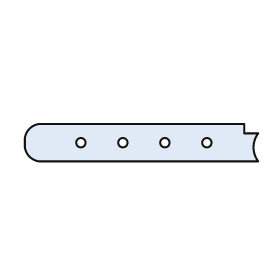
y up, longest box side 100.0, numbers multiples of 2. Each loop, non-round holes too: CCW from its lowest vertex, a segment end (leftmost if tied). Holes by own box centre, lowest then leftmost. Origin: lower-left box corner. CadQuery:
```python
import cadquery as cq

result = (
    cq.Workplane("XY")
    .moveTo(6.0, 0.0)
    .lineTo(100.0, 0.0)
    .threePointArc((98.0, 6.0), (100.0, 12.0))
    .lineTo(94.0, 12.0)
    .lineTo(94.0, 16.0)
    .lineTo(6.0, 16.0)
    .threePointArc((2.0, 14.0), (0.0, 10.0))
    .lineTo(0.0, 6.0)
    .threePointArc((2.0, 2.0), (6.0, 0.0))
    .close()
    .moveTo(24.0, 8.0)
    .circle(2.0)
    .moveTo(42.0, 8.0)
    .circle(2.0)
    .moveTo(60.0, 8.0)
    .circle(2.0)
    .moveTo(78.0, 8.0)
    .circle(2.0)
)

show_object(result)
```